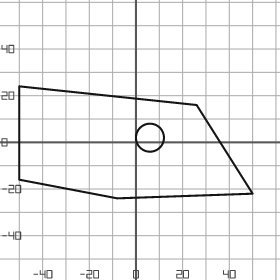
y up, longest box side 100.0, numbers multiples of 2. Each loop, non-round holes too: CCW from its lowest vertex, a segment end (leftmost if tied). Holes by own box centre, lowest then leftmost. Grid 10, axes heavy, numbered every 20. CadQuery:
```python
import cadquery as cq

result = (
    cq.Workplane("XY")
    .moveTo(-8.0, -24.0)
    .lineTo(50.0, -22.0)
    .lineTo(26.0, 16.0)
    .lineTo(-50.0, 24.0)
    .lineTo(-50.0, -16.0)
    .close()
    .moveTo(6.0, 2.0)
    .circle(6.0)
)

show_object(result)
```